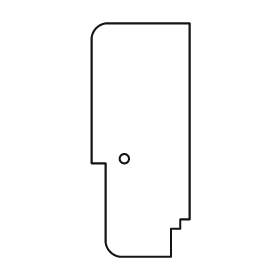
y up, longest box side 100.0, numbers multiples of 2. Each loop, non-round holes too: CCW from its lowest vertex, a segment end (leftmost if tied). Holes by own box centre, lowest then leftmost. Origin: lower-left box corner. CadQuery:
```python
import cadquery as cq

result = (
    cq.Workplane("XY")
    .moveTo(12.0, 0.0)
    .lineTo(34.0, 0.0)
    .lineTo(34.0, 12.0)
    .lineTo(38.0, 12.0)
    .lineTo(38.0, 16.0)
    .lineTo(42.0, 16.0)
    .lineTo(42.0, 100.0)
    .lineTo(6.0, 100.0)
    .threePointArc((2.0, 98.0), (0.0, 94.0))
    .lineTo(0.0, 40.0)
    .lineTo(6.0, 40.0)
    .lineTo(6.0, 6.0)
    .threePointArc((8.0, 2.0), (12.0, 0.0))
    .close()
    .moveTo(14.0, 42.0)
    .circle(2.0)
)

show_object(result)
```